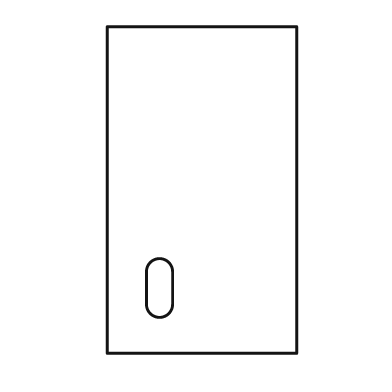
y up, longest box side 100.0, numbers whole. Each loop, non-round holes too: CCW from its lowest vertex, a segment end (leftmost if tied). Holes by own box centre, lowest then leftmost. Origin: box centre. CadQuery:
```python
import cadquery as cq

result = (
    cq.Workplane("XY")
    .moveTo(-29.0, -50.0)
    .lineTo(29.0, -50.0)
    .lineTo(29.0, 50.0)
    .lineTo(-29.0, 50.0)
    .close()
    .moveTo(-17.0, -35.0)
    .threePointArc((-13.0, -39.0), (-9.0, -35.0))
    .lineTo(-9.0, -25.0)
    .threePointArc((-13.0, -21.0), (-17.0, -25.0))
    .close()
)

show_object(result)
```